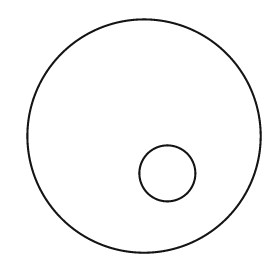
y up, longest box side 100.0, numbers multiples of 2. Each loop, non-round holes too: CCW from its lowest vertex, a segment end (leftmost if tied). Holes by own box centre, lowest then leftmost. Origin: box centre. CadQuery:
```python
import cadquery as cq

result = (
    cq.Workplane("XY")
    .moveTo(0.0, 0.0)
    .circle(50.0)
    .moveTo(10.0, -16.0)
    .circle(12.0)
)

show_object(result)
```